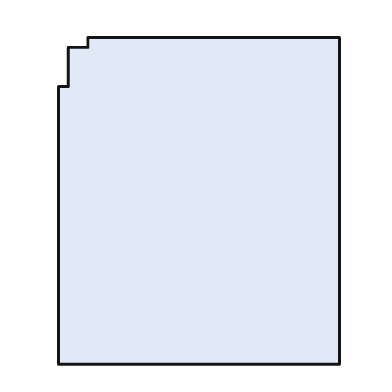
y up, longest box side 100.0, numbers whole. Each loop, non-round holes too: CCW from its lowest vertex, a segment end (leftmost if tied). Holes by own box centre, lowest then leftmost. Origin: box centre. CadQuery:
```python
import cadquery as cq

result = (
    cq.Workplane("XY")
    .moveTo(-43.0, -50.0)
    .lineTo(43.0, -50.0)
    .lineTo(43.0, 50.0)
    .lineTo(-34.0, 50.0)
    .lineTo(-34.0, 47.0)
    .lineTo(-40.0, 47.0)
    .lineTo(-40.0, 35.0)
    .lineTo(-43.0, 35.0)
    .close()
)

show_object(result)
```